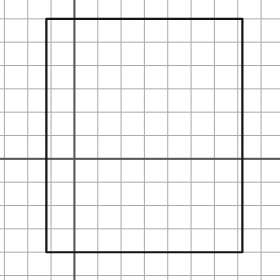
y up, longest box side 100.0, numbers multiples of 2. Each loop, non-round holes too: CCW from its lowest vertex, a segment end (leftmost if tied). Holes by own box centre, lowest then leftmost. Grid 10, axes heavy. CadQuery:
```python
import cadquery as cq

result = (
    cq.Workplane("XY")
    .moveTo(-12.0, -40.0)
    .lineTo(72.0, -40.0)
    .lineTo(72.0, 60.0)
    .lineTo(-12.0, 60.0)
    .close()
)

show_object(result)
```